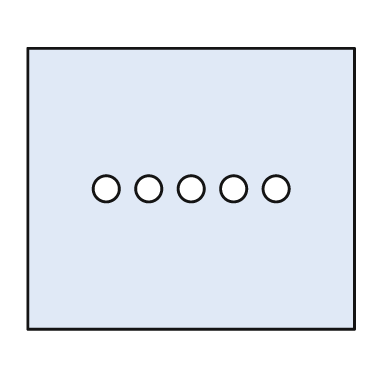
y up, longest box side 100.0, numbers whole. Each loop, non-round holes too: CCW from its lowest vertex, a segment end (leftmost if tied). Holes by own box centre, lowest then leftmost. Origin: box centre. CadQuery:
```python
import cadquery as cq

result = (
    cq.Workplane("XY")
    .moveTo(-50.0, -43.0)
    .lineTo(50.0, -43.0)
    .lineTo(50.0, 43.0)
    .lineTo(-50.0, 43.0)
    .close()
    .moveTo(-26.0, 0.0)
    .circle(4.0)
    .moveTo(-13.0, 0.0)
    .circle(4.0)
    .moveTo(0.0, 0.0)
    .circle(4.0)
    .moveTo(13.0, 0.0)
    .circle(4.0)
    .moveTo(26.0, 0.0)
    .circle(4.0)
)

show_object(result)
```